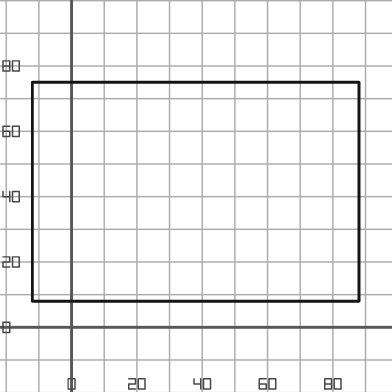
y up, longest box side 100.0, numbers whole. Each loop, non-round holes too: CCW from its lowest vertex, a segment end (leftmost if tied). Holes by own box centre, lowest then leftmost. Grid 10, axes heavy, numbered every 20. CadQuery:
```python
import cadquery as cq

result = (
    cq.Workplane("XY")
    .moveTo(-12.0, 8.0)
    .lineTo(88.0, 8.0)
    .lineTo(88.0, 75.0)
    .lineTo(-12.0, 75.0)
    .close()
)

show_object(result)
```